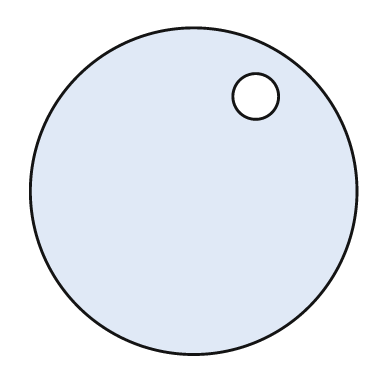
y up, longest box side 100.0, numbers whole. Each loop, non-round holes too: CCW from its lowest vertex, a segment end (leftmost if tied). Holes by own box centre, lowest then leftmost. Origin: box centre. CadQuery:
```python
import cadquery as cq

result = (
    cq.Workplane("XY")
    .moveTo(0.0, 0.0)
    .circle(50.0)
    .moveTo(19.0, 29.0)
    .circle(7.0)
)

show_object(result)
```